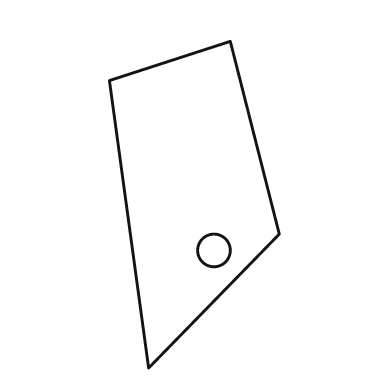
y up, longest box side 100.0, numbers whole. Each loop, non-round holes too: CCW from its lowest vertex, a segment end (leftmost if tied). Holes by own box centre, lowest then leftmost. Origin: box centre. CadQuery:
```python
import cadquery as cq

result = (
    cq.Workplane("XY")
    .moveTo(-14.0, -50.0)
    .lineTo(26.0, -9.0)
    .lineTo(11.0, 50.0)
    .lineTo(-26.0, 38.0)
    .close()
    .moveTo(6.0, -14.0)
    .circle(5.0)
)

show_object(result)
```